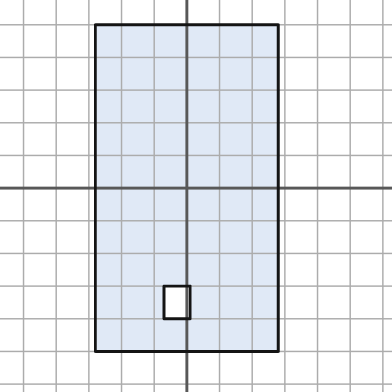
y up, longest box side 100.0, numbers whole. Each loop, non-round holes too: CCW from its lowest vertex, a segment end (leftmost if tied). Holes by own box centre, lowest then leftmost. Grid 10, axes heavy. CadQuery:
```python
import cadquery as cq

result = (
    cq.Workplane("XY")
    .moveTo(-28.0, -50.0)
    .lineTo(28.0, -50.0)
    .lineTo(28.0, 50.0)
    .lineTo(-28.0, 50.0)
    .close()
    .moveTo(-7.0, -40.0)
    .lineTo(1.0, -40.0)
    .lineTo(1.0, -30.0)
    .lineTo(-7.0, -30.0)
    .close()
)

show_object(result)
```